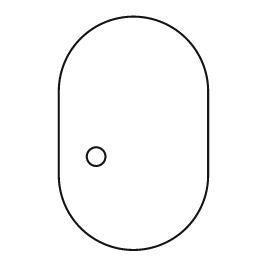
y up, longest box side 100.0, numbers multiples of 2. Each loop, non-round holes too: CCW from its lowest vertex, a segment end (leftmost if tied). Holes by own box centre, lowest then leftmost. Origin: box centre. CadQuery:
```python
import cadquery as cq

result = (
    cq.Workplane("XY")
    .moveTo(-32.0, -18.0)
    .threePointArc((0.0, -50.0), (32.0, -18.0))
    .lineTo(32.0, 18.0)
    .threePointArc((0.0, 50.0), (-32.0, 18.0))
    .close()
    .moveTo(-16.0, -10.0)
    .circle(4.0)
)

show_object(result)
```